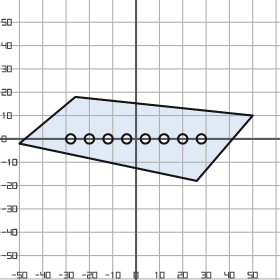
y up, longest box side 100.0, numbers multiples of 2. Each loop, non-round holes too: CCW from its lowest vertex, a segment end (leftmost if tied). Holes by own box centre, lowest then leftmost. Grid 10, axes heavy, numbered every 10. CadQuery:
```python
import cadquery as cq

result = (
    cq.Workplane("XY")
    .moveTo(26.0, -18.0)
    .lineTo(50.0, 10.0)
    .lineTo(-26.0, 18.0)
    .lineTo(-50.0, -2.0)
    .close()
    .moveTo(-28.0, 0.0)
    .circle(2.0)
    .moveTo(-20.0, 0.0)
    .circle(2.0)
    .moveTo(-12.0, 0.0)
    .circle(2.0)
    .moveTo(-4.0, 0.0)
    .circle(2.0)
    .moveTo(4.0, 0.0)
    .circle(2.0)
    .moveTo(12.0, 0.0)
    .circle(2.0)
    .moveTo(20.0, 0.0)
    .circle(2.0)
    .moveTo(28.0, 0.0)
    .circle(2.0)
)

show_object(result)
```